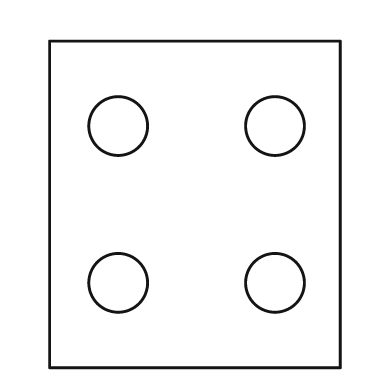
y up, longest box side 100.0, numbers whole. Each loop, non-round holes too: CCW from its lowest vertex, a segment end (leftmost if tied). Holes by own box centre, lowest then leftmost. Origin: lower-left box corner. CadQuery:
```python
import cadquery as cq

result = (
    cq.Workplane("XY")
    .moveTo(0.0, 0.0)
    .lineTo(89.0, 0.0)
    .lineTo(89.0, 100.0)
    .lineTo(0.0, 100.0)
    .close()
    .moveTo(21.0, 26.0)
    .circle(9.0)
    .moveTo(69.0, 26.0)
    .circle(9.0)
    .moveTo(21.0, 74.0)
    .circle(9.0)
    .moveTo(69.0, 74.0)
    .circle(9.0)
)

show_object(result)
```